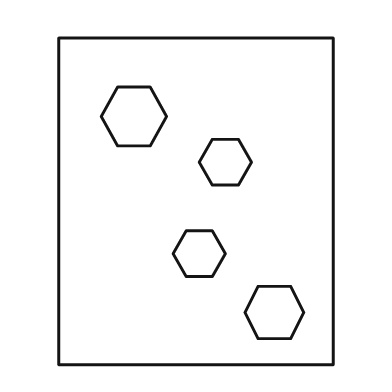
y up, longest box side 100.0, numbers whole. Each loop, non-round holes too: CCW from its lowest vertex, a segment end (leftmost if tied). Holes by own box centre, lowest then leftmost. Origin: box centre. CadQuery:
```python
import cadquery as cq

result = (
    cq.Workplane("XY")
    .moveTo(-42.0, -50.0)
    .lineTo(42.0, -50.0)
    .lineTo(42.0, 50.0)
    .lineTo(-42.0, 50.0)
    .close()
    .moveTo(19.0, -42.0)
    .lineTo(29.0, -42.0)
    .lineTo(33.0, -34.0)
    .lineTo(29.0, -26.0)
    .lineTo(19.0, -26.0)
    .lineTo(15.0, -34.0)
    .close()
    .moveTo(-3.0, -23.0)
    .lineTo(5.0, -23.0)
    .lineTo(9.0, -16.0)
    .lineTo(5.0, -9.0)
    .lineTo(-3.0, -9.0)
    .lineTo(-7.0, -16.0)
    .close()
    .moveTo(5.0, 5.0)
    .lineTo(13.0, 5.0)
    .lineTo(17.0, 12.0)
    .lineTo(13.0, 19.0)
    .lineTo(5.0, 19.0)
    .lineTo(1.0, 12.0)
    .close()
    .moveTo(-24.0, 17.0)
    .lineTo(-14.0, 17.0)
    .lineTo(-9.0, 26.0)
    .lineTo(-14.0, 35.0)
    .lineTo(-24.0, 35.0)
    .lineTo(-29.0, 26.0)
    .close()
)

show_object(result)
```